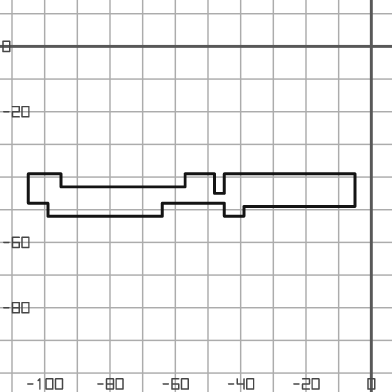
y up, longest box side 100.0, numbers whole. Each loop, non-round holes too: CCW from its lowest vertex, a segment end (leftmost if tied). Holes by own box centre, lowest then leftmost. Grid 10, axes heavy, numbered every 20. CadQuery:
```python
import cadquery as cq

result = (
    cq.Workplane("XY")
    .moveTo(-99.0, -52.0)
    .lineTo(-64.0, -52.0)
    .lineTo(-64.0, -48.0)
    .lineTo(-45.0, -48.0)
    .lineTo(-45.0, -52.0)
    .lineTo(-39.0, -52.0)
    .lineTo(-39.0, -49.0)
    .lineTo(-5.0, -49.0)
    .lineTo(-5.0, -39.0)
    .lineTo(-45.0, -39.0)
    .lineTo(-45.0, -45.0)
    .lineTo(-48.0, -45.0)
    .lineTo(-48.0, -39.0)
    .lineTo(-57.0, -39.0)
    .lineTo(-57.0, -43.0)
    .lineTo(-95.0, -43.0)
    .lineTo(-95.0, -39.0)
    .lineTo(-105.0, -39.0)
    .lineTo(-105.0, -48.0)
    .lineTo(-99.0, -48.0)
    .close()
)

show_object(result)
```